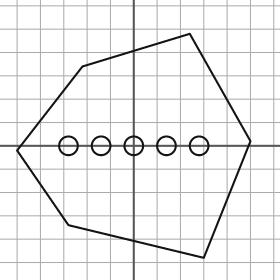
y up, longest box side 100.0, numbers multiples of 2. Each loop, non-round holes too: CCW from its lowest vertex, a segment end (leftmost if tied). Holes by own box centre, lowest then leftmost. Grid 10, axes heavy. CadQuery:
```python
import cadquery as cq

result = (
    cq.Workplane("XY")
    .moveTo(30.0, -48.0)
    .lineTo(50.0, 2.0)
    .lineTo(24.0, 48.0)
    .lineTo(-22.0, 34.0)
    .lineTo(-50.0, -2.0)
    .lineTo(-28.0, -34.0)
    .close()
    .moveTo(-28.0, 0.0)
    .circle(4.0)
    .moveTo(-14.0, 0.0)
    .circle(4.0)
    .moveTo(0.0, 0.0)
    .circle(4.0)
    .moveTo(14.0, 0.0)
    .circle(4.0)
    .moveTo(28.0, 0.0)
    .circle(4.0)
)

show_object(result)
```